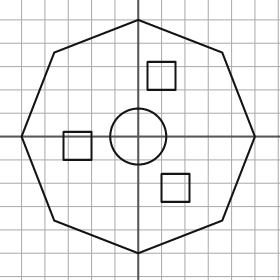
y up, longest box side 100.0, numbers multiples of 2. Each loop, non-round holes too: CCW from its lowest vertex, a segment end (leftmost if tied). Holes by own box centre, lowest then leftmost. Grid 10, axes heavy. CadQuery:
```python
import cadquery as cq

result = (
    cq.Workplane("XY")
    .moveTo(0.0, -50.0)
    .lineTo(36.0, -36.0)
    .lineTo(50.0, 0.0)
    .lineTo(36.0, 36.0)
    .lineTo(0.0, 50.0)
    .lineTo(-36.0, 36.0)
    .lineTo(-50.0, 0.0)
    .lineTo(-36.0, -36.0)
    .close()
    .moveTo(10.0, -28.0)
    .lineTo(22.0, -28.0)
    .lineTo(22.0, -16.0)
    .lineTo(10.0, -16.0)
    .close()
    .moveTo(-32.0, -10.0)
    .lineTo(-20.0, -10.0)
    .lineTo(-20.0, 2.0)
    .lineTo(-32.0, 2.0)
    .close()
    .moveTo(0.0, 0.0)
    .circle(12.0)
    .moveTo(4.0, 20.0)
    .lineTo(16.0, 20.0)
    .lineTo(16.0, 32.0)
    .lineTo(4.0, 32.0)
    .close()
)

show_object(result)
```